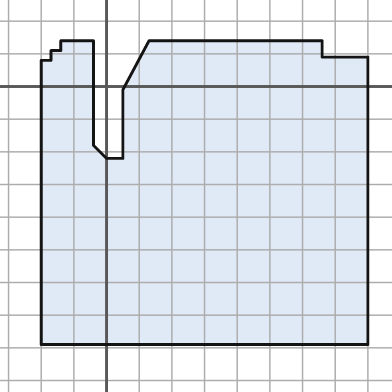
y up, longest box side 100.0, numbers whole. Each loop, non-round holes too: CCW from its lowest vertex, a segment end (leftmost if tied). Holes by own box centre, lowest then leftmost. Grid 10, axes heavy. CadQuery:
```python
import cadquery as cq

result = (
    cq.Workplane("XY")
    .moveTo(-20.0, -79.0)
    .lineTo(80.0, -79.0)
    .lineTo(80.0, 9.0)
    .lineTo(66.0, 9.0)
    .lineTo(66.0, 14.0)
    .lineTo(13.0, 14.0)
    .lineTo(5.0, -1.0)
    .lineTo(5.0, -22.0)
    .lineTo(0.0, -22.0)
    .lineTo(-4.0, -18.0)
    .lineTo(-4.0, 14.0)
    .lineTo(-14.0, 14.0)
    .lineTo(-14.0, 11.0)
    .lineTo(-17.0, 11.0)
    .lineTo(-17.0, 8.0)
    .lineTo(-20.0, 8.0)
    .close()
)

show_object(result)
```